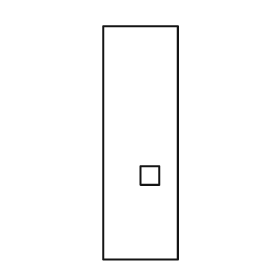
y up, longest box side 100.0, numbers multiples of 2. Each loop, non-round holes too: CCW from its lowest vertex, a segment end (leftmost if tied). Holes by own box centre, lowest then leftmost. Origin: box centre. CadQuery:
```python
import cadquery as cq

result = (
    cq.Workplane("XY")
    .moveTo(-16.0, -50.0)
    .lineTo(16.0, -50.0)
    .lineTo(16.0, 50.0)
    .lineTo(-16.0, 50.0)
    .close()
    .moveTo(0.0, -18.0)
    .lineTo(8.0, -18.0)
    .lineTo(8.0, -10.0)
    .lineTo(0.0, -10.0)
    .close()
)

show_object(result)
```